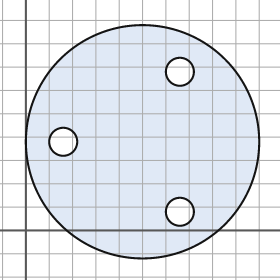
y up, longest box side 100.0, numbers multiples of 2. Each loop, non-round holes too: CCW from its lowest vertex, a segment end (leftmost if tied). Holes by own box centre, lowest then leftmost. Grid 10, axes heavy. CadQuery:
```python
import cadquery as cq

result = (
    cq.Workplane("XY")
    .moveTo(50.0, 38.0)
    .circle(50.0)
    .moveTo(66.0, 8.0)
    .circle(6.0)
    .moveTo(16.0, 38.0)
    .circle(6.0)
    .moveTo(66.0, 68.0)
    .circle(6.0)
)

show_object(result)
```